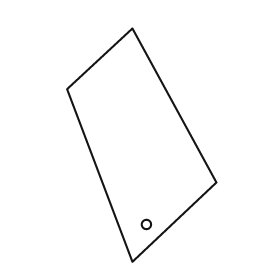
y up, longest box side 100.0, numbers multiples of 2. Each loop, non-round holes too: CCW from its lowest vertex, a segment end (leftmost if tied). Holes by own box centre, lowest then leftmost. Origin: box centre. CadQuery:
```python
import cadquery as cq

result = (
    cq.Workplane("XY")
    .moveTo(-4.0, -50.0)
    .lineTo(32.0, -16.0)
    .lineTo(-4.0, 50.0)
    .lineTo(-32.0, 24.0)
    .close()
    .moveTo(2.0, -34.0)
    .circle(2.0)
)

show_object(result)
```